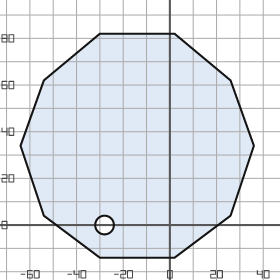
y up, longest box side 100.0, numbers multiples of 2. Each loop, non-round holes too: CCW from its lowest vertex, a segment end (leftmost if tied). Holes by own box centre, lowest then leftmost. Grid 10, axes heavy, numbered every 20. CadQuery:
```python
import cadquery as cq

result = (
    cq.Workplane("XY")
    .moveTo(-30.0, -14.0)
    .lineTo(2.0, -14.0)
    .lineTo(26.0, 4.0)
    .lineTo(36.0, 34.0)
    .lineTo(26.0, 62.0)
    .lineTo(2.0, 82.0)
    .lineTo(-30.0, 82.0)
    .lineTo(-54.0, 62.0)
    .lineTo(-64.0, 34.0)
    .lineTo(-54.0, 4.0)
    .close()
    .moveTo(-28.0, 0.0)
    .circle(4.0)
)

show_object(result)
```